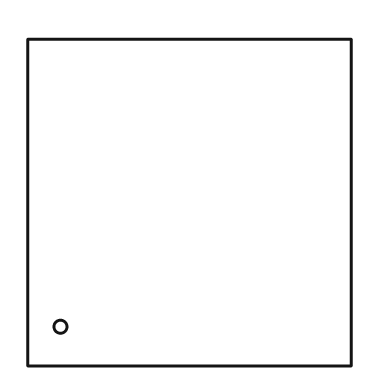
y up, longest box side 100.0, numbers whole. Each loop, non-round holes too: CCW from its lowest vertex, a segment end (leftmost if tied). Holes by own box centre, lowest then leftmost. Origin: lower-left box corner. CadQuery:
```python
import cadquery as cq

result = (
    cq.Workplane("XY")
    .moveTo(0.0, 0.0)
    .lineTo(99.0, 0.0)
    .lineTo(99.0, 100.0)
    .lineTo(0.0, 100.0)
    .close()
    .moveTo(10.0, 12.0)
    .circle(2.0)
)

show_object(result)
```